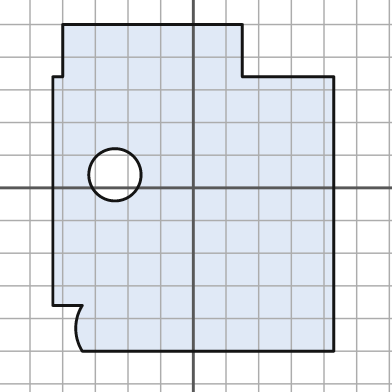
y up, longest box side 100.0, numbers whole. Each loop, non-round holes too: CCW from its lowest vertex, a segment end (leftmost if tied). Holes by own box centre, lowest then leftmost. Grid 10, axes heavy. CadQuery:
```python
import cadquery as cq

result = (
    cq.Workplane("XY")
    .moveTo(-34.0, -50.0)
    .lineTo(43.0, -50.0)
    .lineTo(43.0, 34.0)
    .lineTo(15.0, 34.0)
    .lineTo(15.0, 50.0)
    .lineTo(-40.0, 50.0)
    .lineTo(-40.0, 34.0)
    .lineTo(-43.0, 34.0)
    .lineTo(-43.0, -36.0)
    .lineTo(-34.0, -36.0)
    .threePointArc((-36.0, -43.0), (-34.0, -50.0))
    .close()
    .moveTo(-24.0, 4.0)
    .circle(8.0)
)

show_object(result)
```